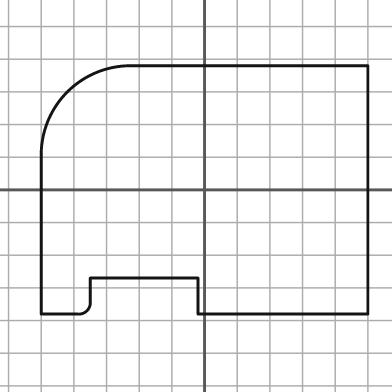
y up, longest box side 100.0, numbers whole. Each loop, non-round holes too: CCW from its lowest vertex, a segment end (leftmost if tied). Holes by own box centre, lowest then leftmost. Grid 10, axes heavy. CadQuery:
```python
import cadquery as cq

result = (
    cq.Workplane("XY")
    .moveTo(-50.0, -38.0)
    .lineTo(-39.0, -38.0)
    .threePointArc((-36.0, -37.0), (-35.0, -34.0))
    .lineTo(-35.0, -27.0)
    .lineTo(-2.0, -27.0)
    .lineTo(-2.0, -38.0)
    .lineTo(50.0, -38.0)
    .lineTo(50.0, 38.0)
    .lineTo(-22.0, 38.0)
    .threePointArc((-42.0, 30.0), (-50.0, 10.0))
    .close()
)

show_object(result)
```